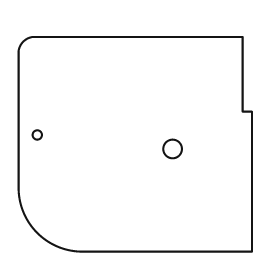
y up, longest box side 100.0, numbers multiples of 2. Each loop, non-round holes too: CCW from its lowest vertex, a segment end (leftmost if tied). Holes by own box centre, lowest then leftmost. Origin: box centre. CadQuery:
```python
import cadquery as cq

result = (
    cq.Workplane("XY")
    .moveTo(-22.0, -46.0)
    .lineTo(50.0, -46.0)
    .lineTo(50.0, 14.0)
    .lineTo(46.0, 14.0)
    .lineTo(46.0, 46.0)
    .lineTo(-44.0, 46.0)
    .threePointArc((-48.0, 44.0), (-50.0, 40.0))
    .lineTo(-50.0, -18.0)
    .threePointArc((-42.0, -38.0), (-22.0, -46.0))
    .close()
    .moveTo(16.0, -2.0)
    .circle(4.0)
    .moveTo(-42.0, 4.0)
    .circle(2.0)
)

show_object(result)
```